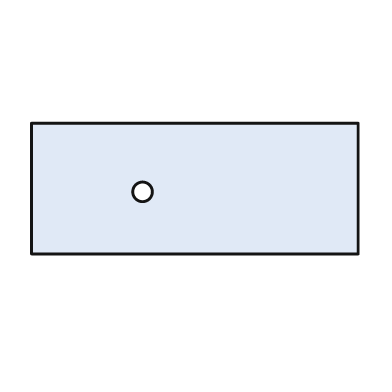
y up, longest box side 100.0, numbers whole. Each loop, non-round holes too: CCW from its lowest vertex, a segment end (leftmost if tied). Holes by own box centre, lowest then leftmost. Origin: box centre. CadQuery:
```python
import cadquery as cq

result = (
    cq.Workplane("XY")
    .moveTo(-50.0, -20.0)
    .lineTo(50.0, -20.0)
    .lineTo(50.0, 20.0)
    .lineTo(-50.0, 20.0)
    .close()
    .moveTo(-16.0, -1.0)
    .circle(3.0)
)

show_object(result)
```